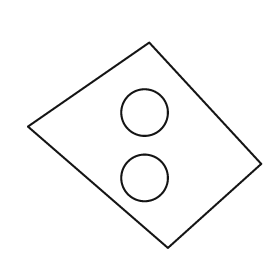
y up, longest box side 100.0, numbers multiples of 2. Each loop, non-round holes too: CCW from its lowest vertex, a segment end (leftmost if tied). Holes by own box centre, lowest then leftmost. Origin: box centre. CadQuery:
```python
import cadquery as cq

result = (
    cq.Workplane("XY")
    .moveTo(10.0, -44.0)
    .lineTo(50.0, -8.0)
    .lineTo(2.0, 44.0)
    .lineTo(-50.0, 8.0)
    .close()
    .moveTo(0.0, -14.0)
    .circle(10.0)
    .moveTo(0.0, 14.0)
    .circle(10.0)
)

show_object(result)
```